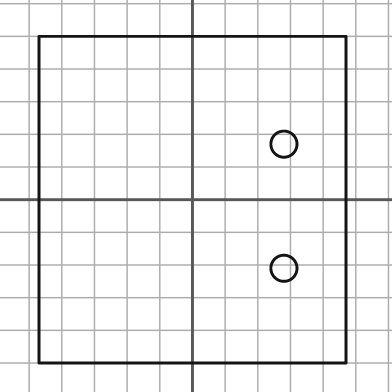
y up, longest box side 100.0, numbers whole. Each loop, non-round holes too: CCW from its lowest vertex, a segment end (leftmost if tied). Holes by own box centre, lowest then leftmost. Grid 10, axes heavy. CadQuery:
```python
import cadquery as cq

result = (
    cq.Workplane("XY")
    .moveTo(-47.0, -50.0)
    .lineTo(47.0, -50.0)
    .lineTo(47.0, 50.0)
    .lineTo(-47.0, 50.0)
    .close()
    .moveTo(28.0, -21.0)
    .circle(4.0)
    .moveTo(28.0, 17.0)
    .circle(4.0)
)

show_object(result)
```